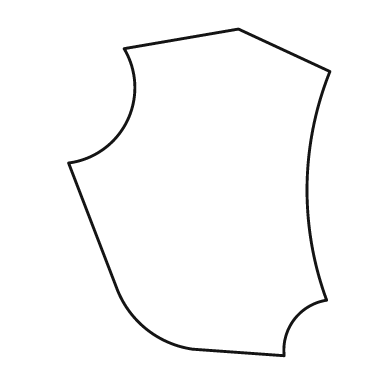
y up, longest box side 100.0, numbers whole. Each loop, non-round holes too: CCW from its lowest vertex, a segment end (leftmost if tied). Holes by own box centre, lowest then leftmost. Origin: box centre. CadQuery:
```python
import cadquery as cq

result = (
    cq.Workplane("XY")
    .moveTo(26.0, -50.0)
    .threePointArc((29.0, -39.0), (39.0, -33.0))
    .threePointArc((33.0, 2.0), (40.0, 37.0))
    .lineTo(12.0, 50.0)
    .lineTo(-23.0, 44.0)
    .threePointArc((-22.0, 22.0), (-40.0, 9.0))
    .lineTo(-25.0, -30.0)
    .threePointArc((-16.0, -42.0), (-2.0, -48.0))
    .close()
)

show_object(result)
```